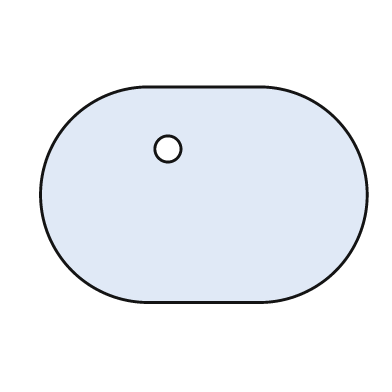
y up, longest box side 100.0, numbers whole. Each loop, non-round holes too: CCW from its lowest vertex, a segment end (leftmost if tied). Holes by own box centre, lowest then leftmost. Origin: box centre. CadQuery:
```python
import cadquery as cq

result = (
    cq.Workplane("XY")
    .moveTo(-17.0, -33.0)
    .lineTo(17.0, -33.0)
    .threePointArc((50.0, 0.0), (17.0, 33.0))
    .lineTo(-17.0, 33.0)
    .threePointArc((-50.0, 0.0), (-17.0, -33.0))
    .close()
    .moveTo(-11.0, 14.0)
    .circle(4.0)
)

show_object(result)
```